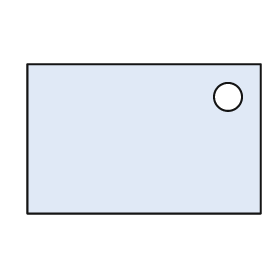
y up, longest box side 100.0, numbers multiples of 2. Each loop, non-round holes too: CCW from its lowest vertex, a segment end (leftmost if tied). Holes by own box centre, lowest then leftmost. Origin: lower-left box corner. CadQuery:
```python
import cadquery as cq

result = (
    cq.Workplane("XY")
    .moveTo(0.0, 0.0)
    .lineTo(100.0, 0.0)
    .lineTo(100.0, 64.0)
    .lineTo(0.0, 64.0)
    .close()
    .moveTo(86.0, 50.0)
    .circle(6.0)
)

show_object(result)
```